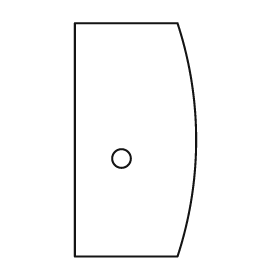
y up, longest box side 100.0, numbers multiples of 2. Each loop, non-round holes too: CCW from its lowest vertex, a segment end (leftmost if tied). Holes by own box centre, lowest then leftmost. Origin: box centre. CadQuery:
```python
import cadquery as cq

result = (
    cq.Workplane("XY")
    .moveTo(-26.0, -50.0)
    .lineTo(18.0, -50.0)
    .threePointArc((26.0, 0.0), (18.0, 50.0))
    .lineTo(-26.0, 50.0)
    .close()
    .moveTo(-6.0, -8.0)
    .circle(4.0)
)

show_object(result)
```